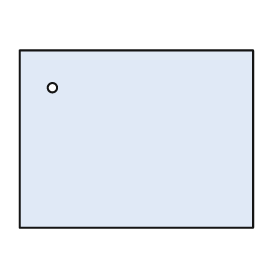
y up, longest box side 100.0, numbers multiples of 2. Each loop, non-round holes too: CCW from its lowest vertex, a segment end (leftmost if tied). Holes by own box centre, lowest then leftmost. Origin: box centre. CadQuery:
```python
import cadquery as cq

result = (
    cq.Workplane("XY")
    .moveTo(-50.0, -38.0)
    .lineTo(50.0, -38.0)
    .lineTo(50.0, 38.0)
    .lineTo(-50.0, 38.0)
    .close()
    .moveTo(-36.0, 22.0)
    .circle(2.0)
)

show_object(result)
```